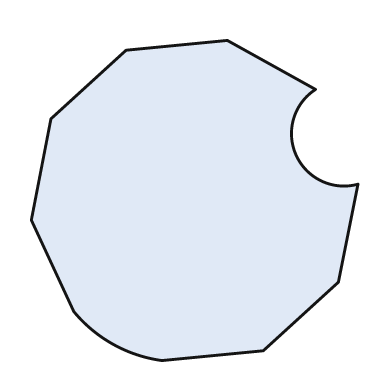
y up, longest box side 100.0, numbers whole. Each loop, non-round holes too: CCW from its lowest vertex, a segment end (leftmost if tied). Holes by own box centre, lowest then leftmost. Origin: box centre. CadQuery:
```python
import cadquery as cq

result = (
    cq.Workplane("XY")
    .moveTo(-10.0, -49.0)
    .lineTo(21.0, -46.0)
    .lineTo(44.0, -25.0)
    .lineTo(50.0, 5.0)
    .threePointArc((31.0, 14.0), (37.0, 34.0))
    .lineTo(10.0, 49.0)
    .lineTo(-21.0, 46.0)
    .lineTo(-44.0, 25.0)
    .lineTo(-50.0, -6.0)
    .lineTo(-37.0, -34.0)
    .threePointArc((-25.0, -44.0), (-10.0, -49.0))
    .close()
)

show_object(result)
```